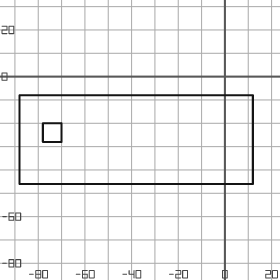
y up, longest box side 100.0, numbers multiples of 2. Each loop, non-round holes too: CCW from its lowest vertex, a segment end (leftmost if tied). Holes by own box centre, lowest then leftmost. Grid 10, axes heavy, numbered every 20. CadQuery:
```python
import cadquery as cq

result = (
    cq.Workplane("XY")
    .moveTo(-88.0, -46.0)
    .lineTo(12.0, -46.0)
    .lineTo(12.0, -8.0)
    .lineTo(-88.0, -8.0)
    .close()
    .moveTo(-78.0, -28.0)
    .lineTo(-70.0, -28.0)
    .lineTo(-70.0, -20.0)
    .lineTo(-78.0, -20.0)
    .close()
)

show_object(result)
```